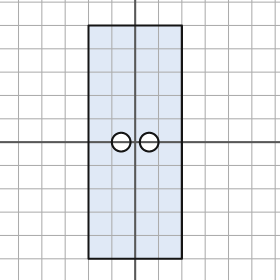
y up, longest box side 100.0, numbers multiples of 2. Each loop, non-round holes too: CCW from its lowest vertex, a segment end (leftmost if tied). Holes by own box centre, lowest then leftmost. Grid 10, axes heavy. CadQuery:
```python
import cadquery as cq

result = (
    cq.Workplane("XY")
    .moveTo(-20.0, -50.0)
    .lineTo(20.0, -50.0)
    .lineTo(20.0, 50.0)
    .lineTo(-20.0, 50.0)
    .close()
    .moveTo(-6.0, 0.0)
    .circle(4.0)
    .moveTo(6.0, 0.0)
    .circle(4.0)
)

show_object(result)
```